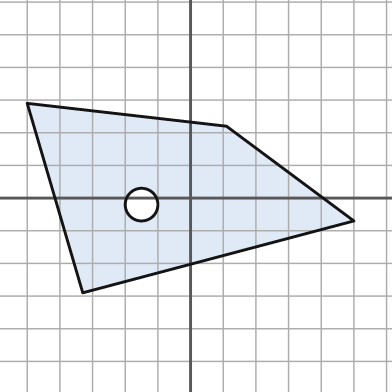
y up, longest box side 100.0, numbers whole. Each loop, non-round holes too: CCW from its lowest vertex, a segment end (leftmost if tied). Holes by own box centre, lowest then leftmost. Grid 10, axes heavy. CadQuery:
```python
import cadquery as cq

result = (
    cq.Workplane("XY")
    .moveTo(-33.0, -29.0)
    .lineTo(50.0, -7.0)
    .lineTo(11.0, 22.0)
    .lineTo(-50.0, 29.0)
    .close()
    .moveTo(-15.0, -2.0)
    .circle(5.0)
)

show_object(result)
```